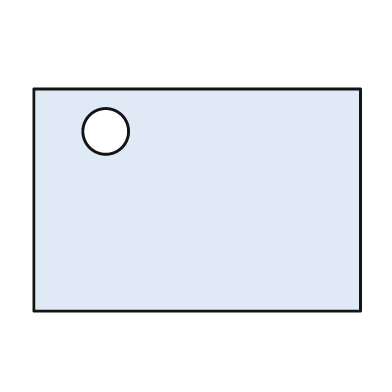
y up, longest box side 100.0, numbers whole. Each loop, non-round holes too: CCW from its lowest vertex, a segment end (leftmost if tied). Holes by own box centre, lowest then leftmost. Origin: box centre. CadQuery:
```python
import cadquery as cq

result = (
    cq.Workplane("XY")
    .moveTo(-50.0, -34.0)
    .lineTo(50.0, -34.0)
    .lineTo(50.0, 34.0)
    .lineTo(-50.0, 34.0)
    .close()
    .moveTo(-28.0, 21.0)
    .circle(7.0)
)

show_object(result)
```